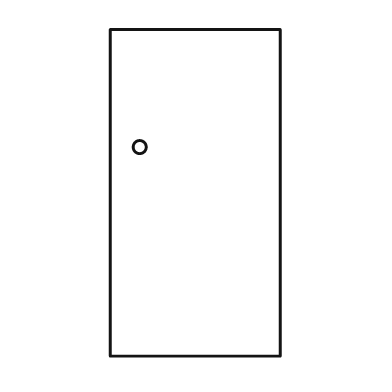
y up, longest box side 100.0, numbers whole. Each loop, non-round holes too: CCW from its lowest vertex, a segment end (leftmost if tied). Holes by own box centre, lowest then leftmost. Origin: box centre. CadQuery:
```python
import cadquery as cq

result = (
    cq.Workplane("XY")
    .moveTo(-26.0, -50.0)
    .lineTo(26.0, -50.0)
    .lineTo(26.0, 50.0)
    .lineTo(-26.0, 50.0)
    .close()
    .moveTo(-17.0, 14.0)
    .circle(2.0)
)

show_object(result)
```